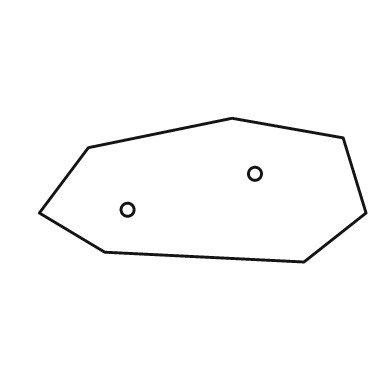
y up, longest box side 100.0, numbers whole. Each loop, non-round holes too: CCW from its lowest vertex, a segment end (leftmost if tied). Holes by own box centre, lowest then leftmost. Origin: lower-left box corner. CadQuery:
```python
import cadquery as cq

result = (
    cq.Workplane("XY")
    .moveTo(81.0, 0.0)
    .lineTo(100.0, 15.0)
    .lineTo(93.0, 38.0)
    .lineTo(59.0, 44.0)
    .lineTo(15.0, 35.0)
    .lineTo(0.0, 15.0)
    .lineTo(20.0, 3.0)
    .close()
    .moveTo(27.0, 16.0)
    .circle(2.0)
    .moveTo(66.0, 27.0)
    .circle(2.0)
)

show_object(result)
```